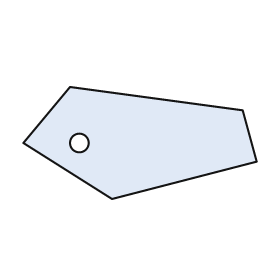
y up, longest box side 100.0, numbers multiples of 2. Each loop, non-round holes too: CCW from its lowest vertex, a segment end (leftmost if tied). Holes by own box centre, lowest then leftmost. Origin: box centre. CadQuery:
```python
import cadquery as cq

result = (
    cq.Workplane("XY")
    .moveTo(-12.0, -24.0)
    .lineTo(50.0, -8.0)
    .lineTo(44.0, 14.0)
    .lineTo(-30.0, 24.0)
    .lineTo(-50.0, 0.0)
    .close()
    .moveTo(-26.0, 0.0)
    .circle(4.0)
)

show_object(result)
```